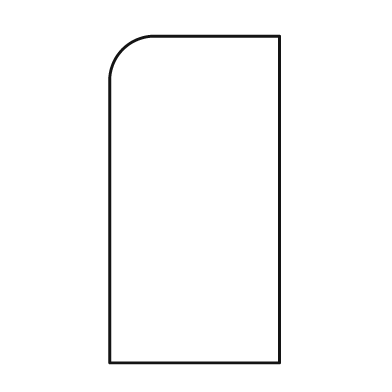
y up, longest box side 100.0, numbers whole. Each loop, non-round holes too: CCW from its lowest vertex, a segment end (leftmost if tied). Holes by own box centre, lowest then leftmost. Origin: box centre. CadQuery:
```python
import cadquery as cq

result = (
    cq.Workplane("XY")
    .moveTo(-26.0, -50.0)
    .lineTo(26.0, -50.0)
    .lineTo(26.0, 50.0)
    .lineTo(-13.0, 50.0)
    .threePointArc((-22.0, 46.0), (-26.0, 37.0))
    .close()
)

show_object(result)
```